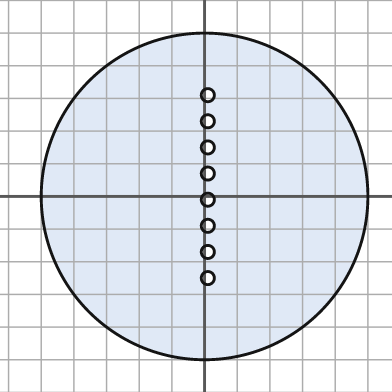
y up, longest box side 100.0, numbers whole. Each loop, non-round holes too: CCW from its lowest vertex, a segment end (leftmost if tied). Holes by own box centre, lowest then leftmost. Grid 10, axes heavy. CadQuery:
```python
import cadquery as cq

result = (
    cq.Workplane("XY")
    .moveTo(0.0, 0.0)
    .circle(50.0)
    .moveTo(1.0, -25.0)
    .circle(2.0)
    .moveTo(1.0, -17.0)
    .circle(2.0)
    .moveTo(1.0, -9.0)
    .circle(2.0)
    .moveTo(1.0, -1.0)
    .circle(2.0)
    .moveTo(1.0, 7.0)
    .circle(2.0)
    .moveTo(1.0, 15.0)
    .circle(2.0)
    .moveTo(1.0, 23.0)
    .circle(2.0)
    .moveTo(1.0, 31.0)
    .circle(2.0)
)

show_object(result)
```